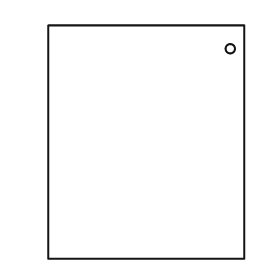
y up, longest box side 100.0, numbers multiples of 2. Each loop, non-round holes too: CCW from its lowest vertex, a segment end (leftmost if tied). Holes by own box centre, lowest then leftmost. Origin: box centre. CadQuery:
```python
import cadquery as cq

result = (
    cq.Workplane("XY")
    .moveTo(-42.0, -50.0)
    .lineTo(42.0, -50.0)
    .lineTo(42.0, 50.0)
    .lineTo(-42.0, 50.0)
    .close()
    .moveTo(36.0, 40.0)
    .circle(2.0)
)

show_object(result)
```